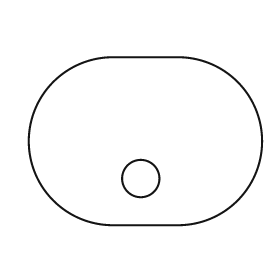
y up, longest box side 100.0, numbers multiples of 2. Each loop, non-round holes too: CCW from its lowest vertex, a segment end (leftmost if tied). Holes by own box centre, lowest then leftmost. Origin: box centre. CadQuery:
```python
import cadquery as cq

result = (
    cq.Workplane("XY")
    .moveTo(-14.0, -36.0)
    .lineTo(14.0, -36.0)
    .threePointArc((50.0, 0.0), (14.0, 36.0))
    .lineTo(-14.0, 36.0)
    .threePointArc((-50.0, 0.0), (-14.0, -36.0))
    .close()
    .moveTo(-2.0, -16.0)
    .circle(8.0)
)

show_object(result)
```